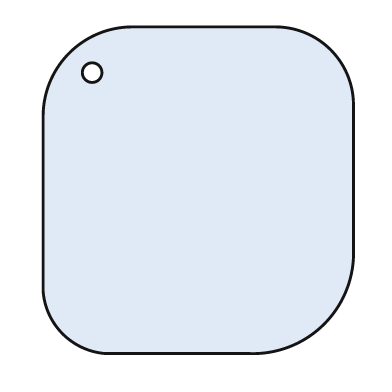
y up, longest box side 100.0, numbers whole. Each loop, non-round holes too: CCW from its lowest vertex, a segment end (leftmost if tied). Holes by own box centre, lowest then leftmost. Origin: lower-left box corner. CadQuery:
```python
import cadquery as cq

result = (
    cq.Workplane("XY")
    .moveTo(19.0, 0.0)
    .lineTo(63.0, 0.0)
    .threePointArc((86.0, 9.0), (95.0, 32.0))
    .lineTo(95.0, 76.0)
    .threePointArc((88.0, 93.0), (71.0, 100.0))
    .lineTo(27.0, 100.0)
    .threePointArc((8.0, 92.0), (0.0, 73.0))
    .lineTo(0.0, 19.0)
    .threePointArc((6.0, 6.0), (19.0, 0.0))
    .close()
    .moveTo(15.0, 86.0)
    .circle(3.0)
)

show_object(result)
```